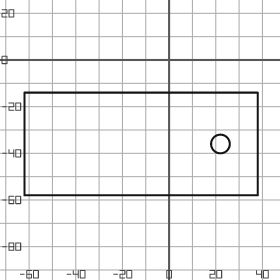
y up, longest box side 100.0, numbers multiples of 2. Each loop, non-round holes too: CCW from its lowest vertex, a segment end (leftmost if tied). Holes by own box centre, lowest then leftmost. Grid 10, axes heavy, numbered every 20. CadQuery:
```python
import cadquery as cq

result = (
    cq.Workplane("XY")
    .moveTo(-62.0, -58.0)
    .lineTo(38.0, -58.0)
    .lineTo(38.0, -14.0)
    .lineTo(-62.0, -14.0)
    .close()
    .moveTo(22.0, -36.0)
    .circle(4.0)
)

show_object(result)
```